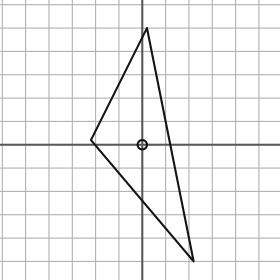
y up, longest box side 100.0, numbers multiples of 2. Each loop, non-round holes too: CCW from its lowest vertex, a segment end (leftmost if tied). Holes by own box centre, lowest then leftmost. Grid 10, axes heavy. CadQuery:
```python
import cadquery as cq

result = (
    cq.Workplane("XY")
    .moveTo(22.0, -50.0)
    .lineTo(2.0, 50.0)
    .lineTo(-22.0, 2.0)
    .close()
    .moveTo(0.0, 0.0)
    .circle(2.0)
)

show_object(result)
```